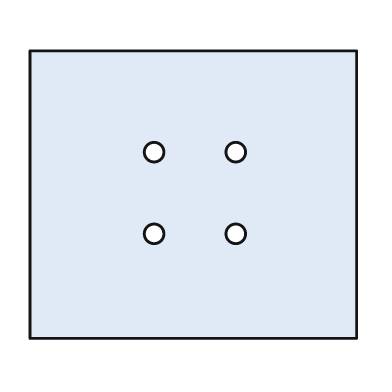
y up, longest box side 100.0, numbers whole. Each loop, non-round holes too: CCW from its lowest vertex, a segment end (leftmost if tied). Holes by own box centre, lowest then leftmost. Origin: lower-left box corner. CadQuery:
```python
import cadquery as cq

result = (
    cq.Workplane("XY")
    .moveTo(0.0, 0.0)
    .lineTo(100.0, 0.0)
    .lineTo(100.0, 88.0)
    .lineTo(0.0, 88.0)
    .close()
    .moveTo(38.0, 32.0)
    .circle(3.0)
    .moveTo(63.0, 32.0)
    .circle(3.0)
    .moveTo(38.0, 57.0)
    .circle(3.0)
    .moveTo(63.0, 57.0)
    .circle(3.0)
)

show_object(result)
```